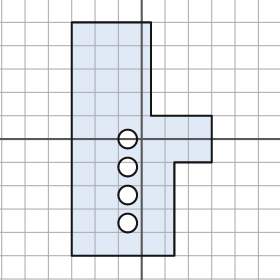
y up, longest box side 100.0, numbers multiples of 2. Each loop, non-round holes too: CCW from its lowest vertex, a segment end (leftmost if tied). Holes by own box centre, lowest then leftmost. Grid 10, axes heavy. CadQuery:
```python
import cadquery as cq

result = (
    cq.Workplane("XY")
    .moveTo(-30.0, -50.0)
    .lineTo(14.0, -50.0)
    .lineTo(14.0, -10.0)
    .lineTo(30.0, -10.0)
    .lineTo(30.0, 10.0)
    .lineTo(4.0, 10.0)
    .lineTo(4.0, 50.0)
    .lineTo(-30.0, 50.0)
    .close()
    .moveTo(-6.0, -36.0)
    .circle(4.0)
    .moveTo(-6.0, -24.0)
    .circle(4.0)
    .moveTo(-6.0, -12.0)
    .circle(4.0)
    .moveTo(-6.0, 0.0)
    .circle(4.0)
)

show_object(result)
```